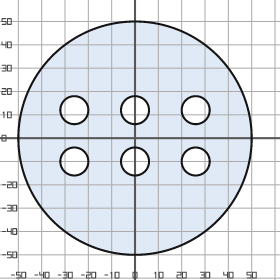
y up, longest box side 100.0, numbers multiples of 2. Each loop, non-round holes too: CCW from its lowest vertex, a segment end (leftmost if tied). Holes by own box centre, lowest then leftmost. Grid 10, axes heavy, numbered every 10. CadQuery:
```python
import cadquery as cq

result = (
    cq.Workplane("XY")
    .moveTo(0.0, 0.0)
    .circle(50.0)
    .moveTo(-26.0, -10.0)
    .circle(6.0)
    .moveTo(0.0, -10.0)
    .circle(6.0)
    .moveTo(26.0, -10.0)
    .circle(6.0)
    .moveTo(-26.0, 12.0)
    .circle(6.0)
    .moveTo(0.0, 12.0)
    .circle(6.0)
    .moveTo(26.0, 12.0)
    .circle(6.0)
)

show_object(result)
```